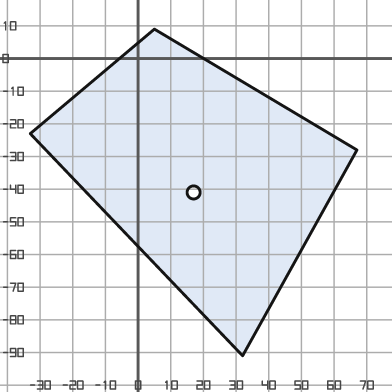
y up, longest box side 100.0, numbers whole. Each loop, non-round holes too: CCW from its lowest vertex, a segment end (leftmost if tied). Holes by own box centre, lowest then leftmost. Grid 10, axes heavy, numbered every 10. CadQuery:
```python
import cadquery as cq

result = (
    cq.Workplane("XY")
    .moveTo(32.0, -91.0)
    .lineTo(67.0, -28.0)
    .lineTo(5.0, 9.0)
    .lineTo(-33.0, -23.0)
    .close()
    .moveTo(17.0, -41.0)
    .circle(2.0)
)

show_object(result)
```